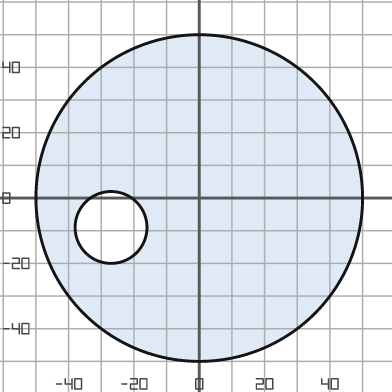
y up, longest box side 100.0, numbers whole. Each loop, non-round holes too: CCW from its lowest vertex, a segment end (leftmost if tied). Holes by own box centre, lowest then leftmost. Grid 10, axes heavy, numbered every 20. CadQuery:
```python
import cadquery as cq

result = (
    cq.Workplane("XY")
    .moveTo(0.0, 0.0)
    .circle(50.0)
    .moveTo(-27.0, -9.0)
    .circle(11.0)
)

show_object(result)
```